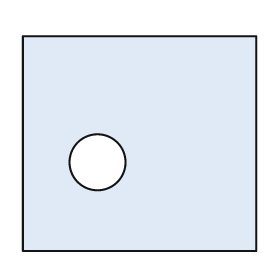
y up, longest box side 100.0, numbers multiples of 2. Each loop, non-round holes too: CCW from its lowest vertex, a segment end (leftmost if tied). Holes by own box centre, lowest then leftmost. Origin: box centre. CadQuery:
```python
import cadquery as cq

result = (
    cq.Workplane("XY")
    .moveTo(-50.0, -46.0)
    .lineTo(50.0, -46.0)
    .lineTo(50.0, 46.0)
    .lineTo(-50.0, 46.0)
    .close()
    .moveTo(-18.0, -8.0)
    .circle(12.0)
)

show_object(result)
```